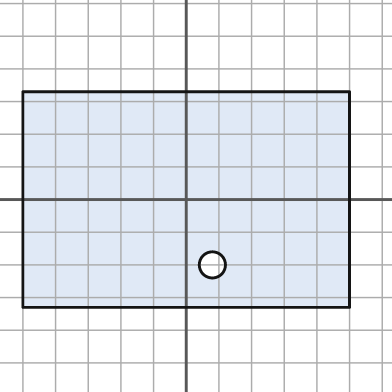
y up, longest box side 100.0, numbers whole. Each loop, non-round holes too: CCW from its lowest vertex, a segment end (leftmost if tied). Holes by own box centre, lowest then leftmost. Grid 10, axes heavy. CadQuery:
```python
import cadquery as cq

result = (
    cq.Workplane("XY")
    .moveTo(-50.0, -33.0)
    .lineTo(50.0, -33.0)
    .lineTo(50.0, 33.0)
    .lineTo(-50.0, 33.0)
    .close()
    .moveTo(8.0, -20.0)
    .circle(4.0)
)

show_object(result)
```